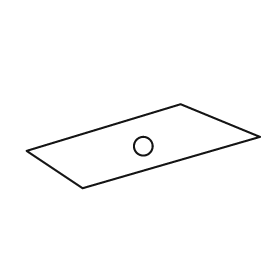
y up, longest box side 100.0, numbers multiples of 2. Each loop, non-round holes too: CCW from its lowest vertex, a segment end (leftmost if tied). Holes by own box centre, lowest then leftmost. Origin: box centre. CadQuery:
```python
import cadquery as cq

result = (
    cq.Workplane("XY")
    .moveTo(-26.0, -18.0)
    .lineTo(50.0, 4.0)
    .lineTo(16.0, 18.0)
    .lineTo(-50.0, -2.0)
    .close()
    .moveTo(0.0, 0.0)
    .circle(4.0)
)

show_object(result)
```